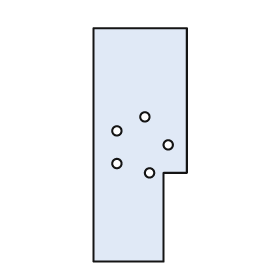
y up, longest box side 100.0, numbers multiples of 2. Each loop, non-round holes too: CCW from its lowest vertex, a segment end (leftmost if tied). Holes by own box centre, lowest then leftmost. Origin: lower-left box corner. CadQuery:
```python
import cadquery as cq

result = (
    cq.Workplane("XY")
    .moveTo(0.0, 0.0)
    .lineTo(30.0, 0.0)
    .lineTo(30.0, 38.0)
    .lineTo(40.0, 38.0)
    .lineTo(40.0, 100.0)
    .lineTo(0.0, 100.0)
    .close()
    .moveTo(24.0, 38.0)
    .circle(2.0)
    .moveTo(10.0, 42.0)
    .circle(2.0)
    .moveTo(32.0, 50.0)
    .circle(2.0)
    .moveTo(10.0, 56.0)
    .circle(2.0)
    .moveTo(22.0, 62.0)
    .circle(2.0)
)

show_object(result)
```